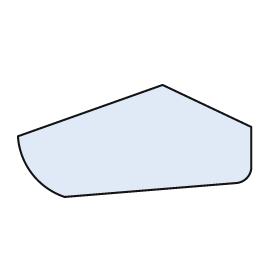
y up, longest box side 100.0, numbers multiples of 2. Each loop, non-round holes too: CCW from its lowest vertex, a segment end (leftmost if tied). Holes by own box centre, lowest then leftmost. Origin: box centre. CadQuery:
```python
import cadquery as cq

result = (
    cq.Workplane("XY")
    .moveTo(-30.0, -24.0)
    .lineTo(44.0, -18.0)
    .threePointArc((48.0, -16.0), (50.0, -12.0))
    .lineTo(50.0, 6.0)
    .lineTo(12.0, 24.0)
    .lineTo(-50.0, 2.0)
    .threePointArc((-44.0, -14.0), (-30.0, -24.0))
    .close()
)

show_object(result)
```